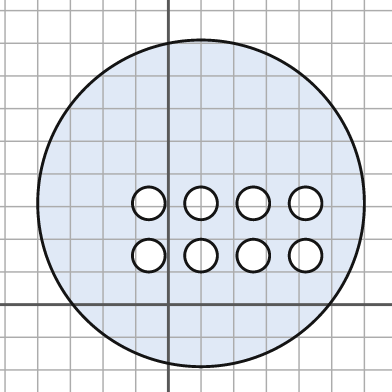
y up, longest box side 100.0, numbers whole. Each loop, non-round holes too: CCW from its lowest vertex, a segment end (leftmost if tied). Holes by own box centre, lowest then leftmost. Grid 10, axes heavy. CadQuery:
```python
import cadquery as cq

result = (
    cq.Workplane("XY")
    .moveTo(10.0, 31.0)
    .circle(50.0)
    .moveTo(-6.0, 15.0)
    .circle(5.0)
    .moveTo(10.0, 15.0)
    .circle(5.0)
    .moveTo(26.0, 15.0)
    .circle(5.0)
    .moveTo(42.0, 15.0)
    .circle(5.0)
    .moveTo(-6.0, 31.0)
    .circle(5.0)
    .moveTo(10.0, 31.0)
    .circle(5.0)
    .moveTo(26.0, 31.0)
    .circle(5.0)
    .moveTo(42.0, 31.0)
    .circle(5.0)
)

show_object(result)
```